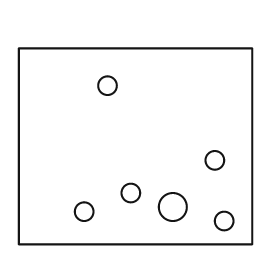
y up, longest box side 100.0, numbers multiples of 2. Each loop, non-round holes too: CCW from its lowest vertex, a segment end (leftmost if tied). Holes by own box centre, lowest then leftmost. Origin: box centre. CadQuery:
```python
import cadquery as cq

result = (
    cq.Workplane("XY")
    .moveTo(-50.0, -42.0)
    .lineTo(50.0, -42.0)
    .lineTo(50.0, 42.0)
    .lineTo(-50.0, 42.0)
    .close()
    .moveTo(38.0, -32.0)
    .circle(4.0)
    .moveTo(-22.0, -28.0)
    .circle(4.0)
    .moveTo(16.0, -26.0)
    .circle(6.0)
    .moveTo(-2.0, -20.0)
    .circle(4.0)
    .moveTo(34.0, -6.0)
    .circle(4.0)
    .moveTo(-12.0, 26.0)
    .circle(4.0)
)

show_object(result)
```